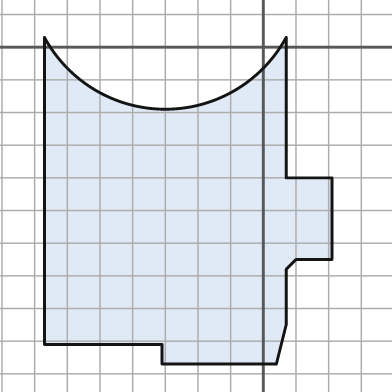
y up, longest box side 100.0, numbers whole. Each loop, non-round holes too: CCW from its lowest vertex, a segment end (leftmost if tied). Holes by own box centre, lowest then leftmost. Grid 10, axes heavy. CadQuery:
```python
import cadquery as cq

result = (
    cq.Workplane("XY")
    .moveTo(-31.0, -97.0)
    .lineTo(4.0, -97.0)
    .lineTo(7.0, -85.0)
    .lineTo(7.0, -68.0)
    .lineTo(10.0, -65.0)
    .lineTo(21.0, -65.0)
    .lineTo(21.0, -40.0)
    .lineTo(7.0, -40.0)
    .lineTo(7.0, 3.0)
    .threePointArc((-30.0, -19.0), (-67.0, 3.0))
    .lineTo(-67.0, -91.0)
    .lineTo(-31.0, -91.0)
    .close()
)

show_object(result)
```